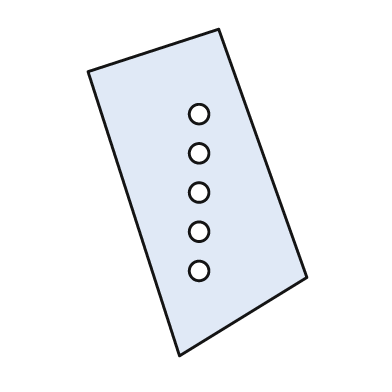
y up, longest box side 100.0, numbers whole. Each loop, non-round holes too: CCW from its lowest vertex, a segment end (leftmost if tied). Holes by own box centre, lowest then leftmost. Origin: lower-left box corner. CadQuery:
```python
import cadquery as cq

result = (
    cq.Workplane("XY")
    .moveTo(28.0, 0.0)
    .lineTo(67.0, 24.0)
    .lineTo(40.0, 100.0)
    .lineTo(0.0, 87.0)
    .close()
    .moveTo(34.0, 26.0)
    .circle(3.0)
    .moveTo(34.0, 38.0)
    .circle(3.0)
    .moveTo(34.0, 50.0)
    .circle(3.0)
    .moveTo(34.0, 62.0)
    .circle(3.0)
    .moveTo(34.0, 74.0)
    .circle(3.0)
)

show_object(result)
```